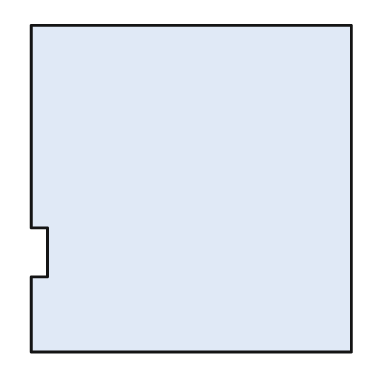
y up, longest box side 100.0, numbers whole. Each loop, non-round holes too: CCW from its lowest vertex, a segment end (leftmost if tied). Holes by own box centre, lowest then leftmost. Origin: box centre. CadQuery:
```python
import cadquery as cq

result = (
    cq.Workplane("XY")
    .moveTo(-49.0, -50.0)
    .lineTo(49.0, -50.0)
    .lineTo(49.0, 50.0)
    .lineTo(-49.0, 50.0)
    .lineTo(-49.0, -12.0)
    .lineTo(-44.0, -12.0)
    .lineTo(-44.0, -27.0)
    .lineTo(-49.0, -27.0)
    .close()
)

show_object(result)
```